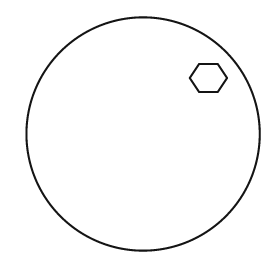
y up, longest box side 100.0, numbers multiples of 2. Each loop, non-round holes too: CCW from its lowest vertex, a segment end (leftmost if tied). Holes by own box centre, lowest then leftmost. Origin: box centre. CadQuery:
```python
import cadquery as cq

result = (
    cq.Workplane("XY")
    .moveTo(0.0, 0.0)
    .circle(50.0)
    .moveTo(24.0, 18.0)
    .lineTo(32.0, 18.0)
    .lineTo(36.0, 24.0)
    .lineTo(32.0, 30.0)
    .lineTo(24.0, 30.0)
    .lineTo(20.0, 24.0)
    .close()
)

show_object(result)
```